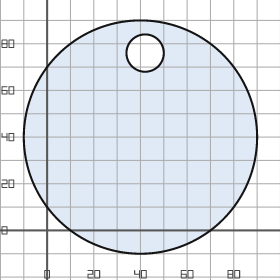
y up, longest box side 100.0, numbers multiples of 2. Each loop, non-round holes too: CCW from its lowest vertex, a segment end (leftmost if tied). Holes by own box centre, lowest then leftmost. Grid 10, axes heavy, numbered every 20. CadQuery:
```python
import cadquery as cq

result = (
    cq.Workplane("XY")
    .moveTo(40.0, 40.0)
    .circle(50.0)
    .moveTo(42.0, 76.0)
    .circle(8.0)
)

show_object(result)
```